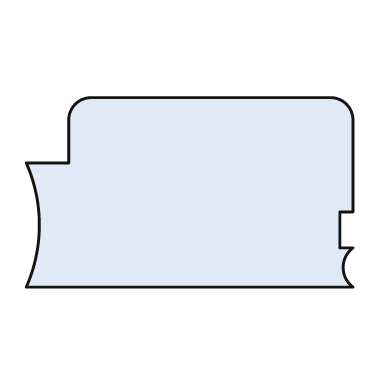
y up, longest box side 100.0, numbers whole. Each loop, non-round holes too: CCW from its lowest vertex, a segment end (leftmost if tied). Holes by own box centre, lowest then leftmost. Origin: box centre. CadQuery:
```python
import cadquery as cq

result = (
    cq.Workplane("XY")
    .moveTo(-50.0, -29.0)
    .lineTo(50.0, -29.0)
    .threePointArc((47.0, -23.0), (50.0, -17.0))
    .lineTo(46.0, -17.0)
    .lineTo(46.0, -6.0)
    .lineTo(50.0, -6.0)
    .lineTo(50.0, 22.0)
    .threePointArc((48.0, 27.0), (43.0, 29.0))
    .lineTo(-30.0, 29.0)
    .threePointArc((-35.0, 27.0), (-37.0, 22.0))
    .lineTo(-37.0, 9.0)
    .lineTo(-50.0, 9.0)
    .threePointArc((-46.0, -10.0), (-50.0, -29.0))
    .close()
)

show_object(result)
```